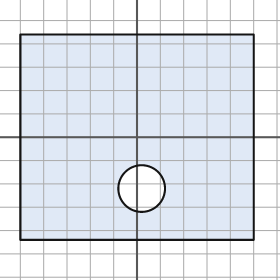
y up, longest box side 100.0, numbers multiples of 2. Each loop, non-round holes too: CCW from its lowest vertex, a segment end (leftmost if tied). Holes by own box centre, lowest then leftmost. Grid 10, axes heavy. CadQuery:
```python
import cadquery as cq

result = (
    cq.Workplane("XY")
    .moveTo(-50.0, -44.0)
    .lineTo(50.0, -44.0)
    .lineTo(50.0, 44.0)
    .lineTo(-50.0, 44.0)
    .close()
    .moveTo(2.0, -22.0)
    .circle(10.0)
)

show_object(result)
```